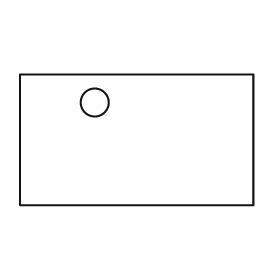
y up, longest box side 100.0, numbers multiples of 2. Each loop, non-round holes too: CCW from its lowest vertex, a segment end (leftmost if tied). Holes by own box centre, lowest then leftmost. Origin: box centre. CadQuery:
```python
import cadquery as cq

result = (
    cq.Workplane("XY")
    .moveTo(-50.0, -28.0)
    .lineTo(50.0, -28.0)
    .lineTo(50.0, 28.0)
    .lineTo(-50.0, 28.0)
    .close()
    .moveTo(-18.0, 16.0)
    .circle(6.0)
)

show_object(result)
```